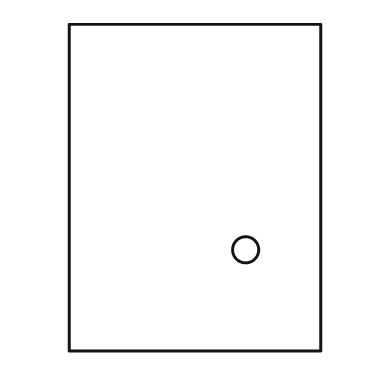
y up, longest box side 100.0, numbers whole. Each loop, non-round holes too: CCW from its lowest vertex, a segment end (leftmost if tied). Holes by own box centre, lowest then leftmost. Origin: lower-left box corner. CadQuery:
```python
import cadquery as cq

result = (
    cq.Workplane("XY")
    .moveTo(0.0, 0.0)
    .lineTo(77.0, 0.0)
    .lineTo(77.0, 100.0)
    .lineTo(0.0, 100.0)
    .close()
    .moveTo(54.0, 31.0)
    .circle(4.0)
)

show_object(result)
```